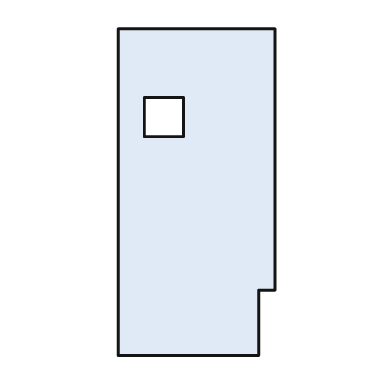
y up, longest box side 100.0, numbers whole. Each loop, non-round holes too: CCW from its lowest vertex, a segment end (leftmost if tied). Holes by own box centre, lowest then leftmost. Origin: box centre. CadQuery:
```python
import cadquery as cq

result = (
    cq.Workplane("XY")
    .moveTo(-24.0, -50.0)
    .lineTo(19.0, -50.0)
    .lineTo(19.0, -30.0)
    .lineTo(24.0, -30.0)
    .lineTo(24.0, 50.0)
    .lineTo(-24.0, 50.0)
    .close()
    .moveTo(-16.0, 17.0)
    .lineTo(-4.0, 17.0)
    .lineTo(-4.0, 29.0)
    .lineTo(-16.0, 29.0)
    .close()
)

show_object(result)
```